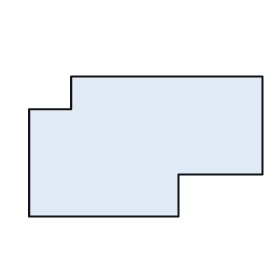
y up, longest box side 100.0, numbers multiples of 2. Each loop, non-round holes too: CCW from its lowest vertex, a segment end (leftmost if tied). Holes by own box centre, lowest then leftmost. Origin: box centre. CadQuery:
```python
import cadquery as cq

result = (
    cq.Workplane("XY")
    .moveTo(-50.0, -30.0)
    .lineTo(14.0, -30.0)
    .lineTo(14.0, -12.0)
    .lineTo(50.0, -12.0)
    .lineTo(50.0, 30.0)
    .lineTo(-32.0, 30.0)
    .lineTo(-32.0, 16.0)
    .lineTo(-50.0, 16.0)
    .close()
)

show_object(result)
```